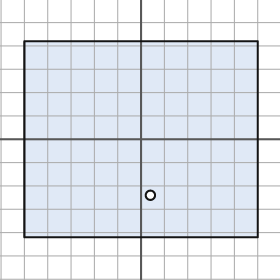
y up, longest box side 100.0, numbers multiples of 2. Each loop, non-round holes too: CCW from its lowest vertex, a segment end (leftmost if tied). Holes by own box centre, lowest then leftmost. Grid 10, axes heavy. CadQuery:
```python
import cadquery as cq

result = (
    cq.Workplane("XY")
    .moveTo(-50.0, -42.0)
    .lineTo(50.0, -42.0)
    .lineTo(50.0, 42.0)
    .lineTo(-50.0, 42.0)
    .close()
    .moveTo(4.0, -24.0)
    .circle(2.0)
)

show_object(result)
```